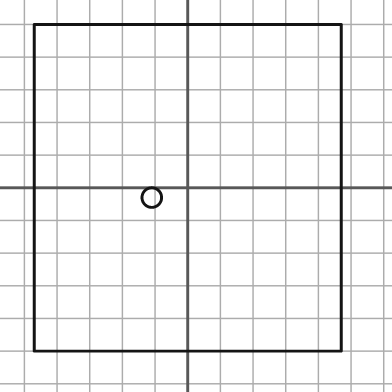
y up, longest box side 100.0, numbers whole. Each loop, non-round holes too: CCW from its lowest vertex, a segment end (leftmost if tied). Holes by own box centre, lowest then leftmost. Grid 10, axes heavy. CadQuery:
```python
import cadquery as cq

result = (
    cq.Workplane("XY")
    .moveTo(-47.0, -50.0)
    .lineTo(47.0, -50.0)
    .lineTo(47.0, 50.0)
    .lineTo(-47.0, 50.0)
    .close()
    .moveTo(-11.0, -3.0)
    .circle(3.0)
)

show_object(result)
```